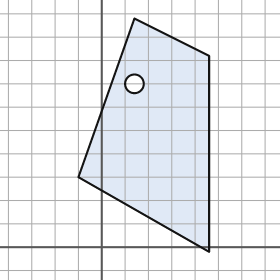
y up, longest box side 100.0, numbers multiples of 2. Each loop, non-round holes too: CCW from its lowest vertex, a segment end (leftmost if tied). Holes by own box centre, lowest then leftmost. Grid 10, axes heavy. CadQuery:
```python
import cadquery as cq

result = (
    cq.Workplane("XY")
    .moveTo(46.0, -2.0)
    .lineTo(46.0, 82.0)
    .lineTo(14.0, 98.0)
    .lineTo(-10.0, 30.0)
    .close()
    .moveTo(14.0, 70.0)
    .circle(4.0)
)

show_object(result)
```